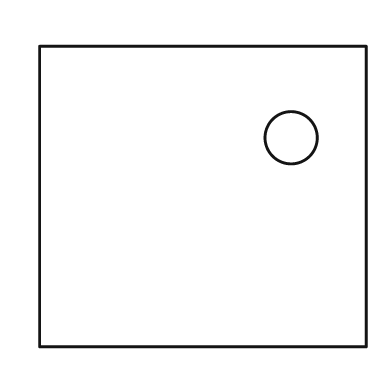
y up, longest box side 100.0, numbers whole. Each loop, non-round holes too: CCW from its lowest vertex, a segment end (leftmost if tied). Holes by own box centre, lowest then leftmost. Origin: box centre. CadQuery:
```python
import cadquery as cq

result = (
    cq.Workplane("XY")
    .moveTo(-50.0, -46.0)
    .lineTo(50.0, -46.0)
    .lineTo(50.0, 46.0)
    .lineTo(-50.0, 46.0)
    .close()
    .moveTo(27.0, 18.0)
    .circle(8.0)
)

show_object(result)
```